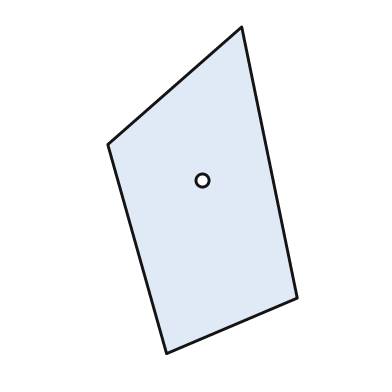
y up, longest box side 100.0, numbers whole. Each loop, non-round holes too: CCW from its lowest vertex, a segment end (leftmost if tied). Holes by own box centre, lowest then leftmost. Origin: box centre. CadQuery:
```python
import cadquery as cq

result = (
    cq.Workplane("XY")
    .moveTo(-11.0, -50.0)
    .lineTo(29.0, -33.0)
    .lineTo(12.0, 50.0)
    .lineTo(-29.0, 14.0)
    .close()
    .moveTo(0.0, 3.0)
    .circle(2.0)
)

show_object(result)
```